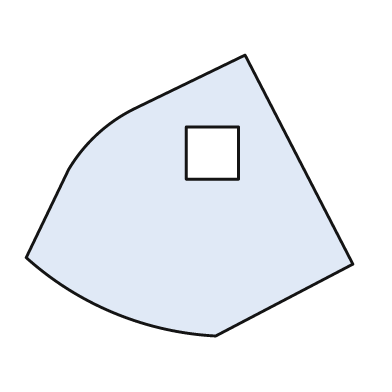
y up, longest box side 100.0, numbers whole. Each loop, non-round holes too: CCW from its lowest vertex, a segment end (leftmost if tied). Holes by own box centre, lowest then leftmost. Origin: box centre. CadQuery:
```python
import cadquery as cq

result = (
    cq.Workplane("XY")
    .moveTo(8.0, -43.0)
    .lineTo(50.0, -21.0)
    .lineTo(17.0, 43.0)
    .lineTo(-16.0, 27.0)
    .threePointArc((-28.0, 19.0), (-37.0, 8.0))
    .lineTo(-50.0, -19.0)
    .threePointArc((-23.0, -36.0), (8.0, -43.0))
    .close()
    .moveTo(-1.0, 5.0)
    .lineTo(15.0, 5.0)
    .lineTo(15.0, 21.0)
    .lineTo(-1.0, 21.0)
    .close()
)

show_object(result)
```